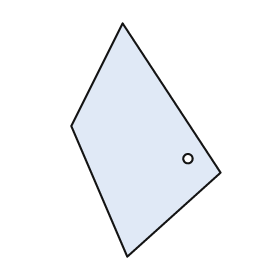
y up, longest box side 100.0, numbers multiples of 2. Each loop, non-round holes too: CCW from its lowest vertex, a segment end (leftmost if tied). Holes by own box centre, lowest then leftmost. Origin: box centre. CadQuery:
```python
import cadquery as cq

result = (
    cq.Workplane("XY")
    .moveTo(-8.0, -50.0)
    .lineTo(32.0, -14.0)
    .lineTo(-10.0, 50.0)
    .lineTo(-32.0, 6.0)
    .close()
    .moveTo(18.0, -8.0)
    .circle(2.0)
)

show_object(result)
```